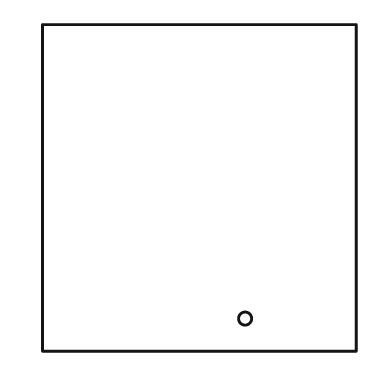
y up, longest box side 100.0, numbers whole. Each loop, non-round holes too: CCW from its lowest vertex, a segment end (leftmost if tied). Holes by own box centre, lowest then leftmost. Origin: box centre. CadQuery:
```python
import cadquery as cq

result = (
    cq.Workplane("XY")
    .moveTo(-48.0, -50.0)
    .lineTo(48.0, -50.0)
    .lineTo(48.0, 50.0)
    .lineTo(-48.0, 50.0)
    .close()
    .moveTo(14.0, -40.0)
    .circle(2.0)
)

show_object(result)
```